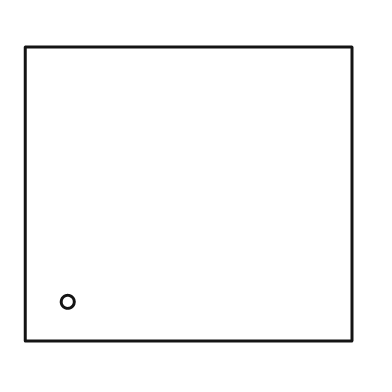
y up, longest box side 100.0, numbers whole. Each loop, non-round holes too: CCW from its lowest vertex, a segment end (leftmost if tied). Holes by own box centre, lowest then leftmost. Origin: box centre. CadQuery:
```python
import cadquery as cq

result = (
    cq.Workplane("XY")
    .moveTo(-50.0, -45.0)
    .lineTo(50.0, -45.0)
    .lineTo(50.0, 45.0)
    .lineTo(-50.0, 45.0)
    .close()
    .moveTo(-37.0, -33.0)
    .circle(2.0)
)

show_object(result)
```